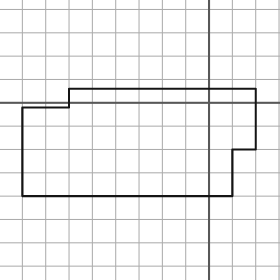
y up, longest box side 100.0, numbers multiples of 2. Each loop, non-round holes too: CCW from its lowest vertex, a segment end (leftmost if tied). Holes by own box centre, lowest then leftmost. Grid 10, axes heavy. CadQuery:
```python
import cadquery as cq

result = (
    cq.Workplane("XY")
    .moveTo(-80.0, -40.0)
    .lineTo(10.0, -40.0)
    .lineTo(10.0, -20.0)
    .lineTo(20.0, -20.0)
    .lineTo(20.0, 6.0)
    .lineTo(-60.0, 6.0)
    .lineTo(-60.0, -2.0)
    .lineTo(-80.0, -2.0)
    .close()
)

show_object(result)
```